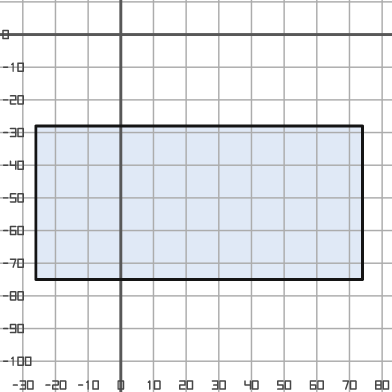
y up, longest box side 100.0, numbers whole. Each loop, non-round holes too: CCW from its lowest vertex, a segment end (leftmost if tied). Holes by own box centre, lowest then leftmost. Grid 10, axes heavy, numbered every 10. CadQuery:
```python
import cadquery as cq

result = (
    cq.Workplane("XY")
    .moveTo(-26.0, -75.0)
    .lineTo(74.0, -75.0)
    .lineTo(74.0, -28.0)
    .lineTo(-26.0, -28.0)
    .close()
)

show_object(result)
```